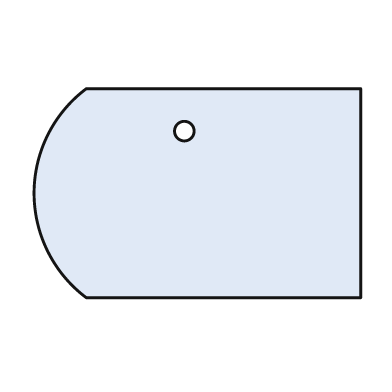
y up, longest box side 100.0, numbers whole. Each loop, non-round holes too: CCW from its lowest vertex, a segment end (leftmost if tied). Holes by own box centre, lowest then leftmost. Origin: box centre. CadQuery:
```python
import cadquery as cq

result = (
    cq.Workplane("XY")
    .moveTo(-34.0, -32.0)
    .lineTo(50.0, -32.0)
    .lineTo(50.0, 32.0)
    .lineTo(-34.0, 32.0)
    .threePointArc((-50.0, 0.0), (-34.0, -32.0))
    .close()
    .moveTo(-4.0, 19.0)
    .circle(3.0)
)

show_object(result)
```